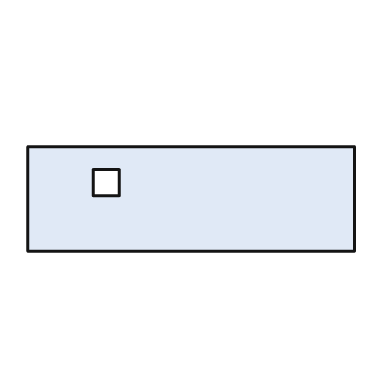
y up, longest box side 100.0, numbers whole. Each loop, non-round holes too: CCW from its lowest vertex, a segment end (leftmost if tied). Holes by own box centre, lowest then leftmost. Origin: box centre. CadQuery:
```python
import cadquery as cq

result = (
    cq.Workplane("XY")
    .moveTo(-50.0, -16.0)
    .lineTo(50.0, -16.0)
    .lineTo(50.0, 16.0)
    .lineTo(-50.0, 16.0)
    .close()
    .moveTo(-30.0, 1.0)
    .lineTo(-22.0, 1.0)
    .lineTo(-22.0, 9.0)
    .lineTo(-30.0, 9.0)
    .close()
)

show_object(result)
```